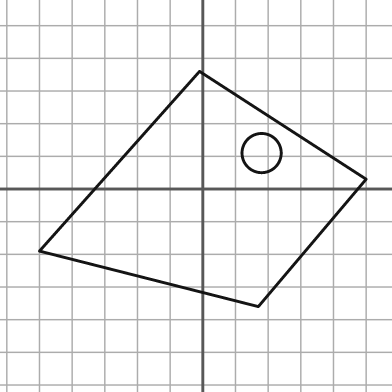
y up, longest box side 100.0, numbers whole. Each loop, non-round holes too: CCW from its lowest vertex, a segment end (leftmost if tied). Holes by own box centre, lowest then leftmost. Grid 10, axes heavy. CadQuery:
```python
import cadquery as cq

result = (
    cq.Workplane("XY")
    .moveTo(17.0, -36.0)
    .lineTo(50.0, 3.0)
    .lineTo(-1.0, 36.0)
    .lineTo(-50.0, -19.0)
    .close()
    .moveTo(18.0, 11.0)
    .circle(6.0)
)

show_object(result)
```